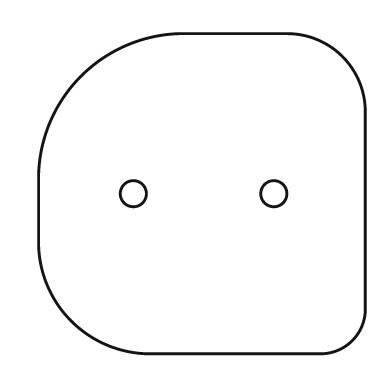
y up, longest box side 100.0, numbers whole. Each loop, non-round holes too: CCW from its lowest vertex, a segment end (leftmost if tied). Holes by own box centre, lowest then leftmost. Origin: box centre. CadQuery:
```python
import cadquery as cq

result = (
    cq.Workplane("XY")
    .moveTo(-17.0, -49.0)
    .lineTo(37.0, -49.0)
    .threePointArc((46.0, -45.0), (50.0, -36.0))
    .lineTo(50.0, 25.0)
    .threePointArc((43.0, 42.0), (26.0, 49.0))
    .lineTo(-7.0, 49.0)
    .threePointArc((-37.0, 36.0), (-50.0, 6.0))
    .lineTo(-50.0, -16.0)
    .threePointArc((-40.0, -39.0), (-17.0, -49.0))
    .close()
    .moveTo(-21.0, 0.0)
    .circle(4.0)
    .moveTo(22.0, 0.0)
    .circle(4.0)
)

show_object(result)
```